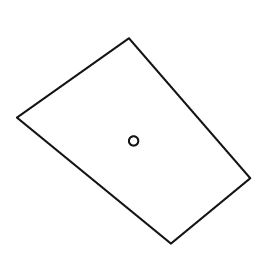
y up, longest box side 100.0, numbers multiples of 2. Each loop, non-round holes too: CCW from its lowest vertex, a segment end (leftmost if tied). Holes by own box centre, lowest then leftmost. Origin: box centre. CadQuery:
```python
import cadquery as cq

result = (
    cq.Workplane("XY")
    .moveTo(16.0, -44.0)
    .lineTo(50.0, -16.0)
    .lineTo(-2.0, 44.0)
    .lineTo(-50.0, 10.0)
    .close()
    .moveTo(0.0, 0.0)
    .circle(2.0)
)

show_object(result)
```